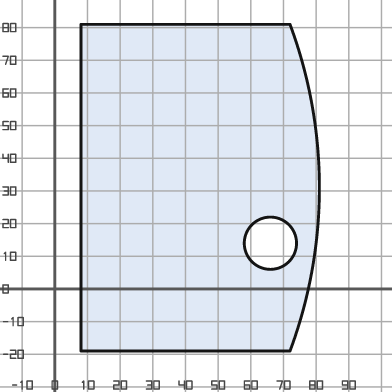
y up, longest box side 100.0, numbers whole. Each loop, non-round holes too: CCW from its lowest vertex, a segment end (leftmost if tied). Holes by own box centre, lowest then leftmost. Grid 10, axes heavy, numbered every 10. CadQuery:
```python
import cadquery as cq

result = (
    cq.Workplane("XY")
    .moveTo(8.0, -19.0)
    .lineTo(72.0, -19.0)
    .threePointArc((81.0, 31.0), (72.0, 81.0))
    .lineTo(8.0, 81.0)
    .close()
    .moveTo(66.0, 14.0)
    .circle(8.0)
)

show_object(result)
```